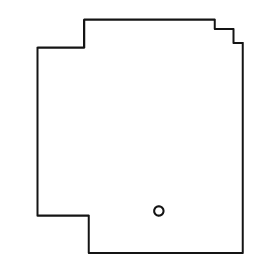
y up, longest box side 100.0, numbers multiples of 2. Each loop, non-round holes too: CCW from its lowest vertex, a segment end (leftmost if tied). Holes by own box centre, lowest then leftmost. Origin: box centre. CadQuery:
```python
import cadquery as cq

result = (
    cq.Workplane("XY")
    .moveTo(-22.0, -50.0)
    .lineTo(44.0, -50.0)
    .lineTo(44.0, 40.0)
    .lineTo(40.0, 40.0)
    .lineTo(40.0, 46.0)
    .lineTo(32.0, 46.0)
    .lineTo(32.0, 50.0)
    .lineTo(-24.0, 50.0)
    .lineTo(-24.0, 38.0)
    .lineTo(-44.0, 38.0)
    .lineTo(-44.0, -34.0)
    .lineTo(-22.0, -34.0)
    .close()
    .moveTo(8.0, -32.0)
    .circle(2.0)
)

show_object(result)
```